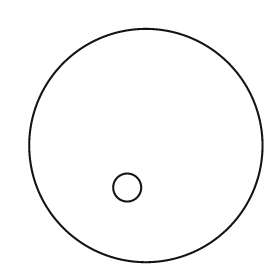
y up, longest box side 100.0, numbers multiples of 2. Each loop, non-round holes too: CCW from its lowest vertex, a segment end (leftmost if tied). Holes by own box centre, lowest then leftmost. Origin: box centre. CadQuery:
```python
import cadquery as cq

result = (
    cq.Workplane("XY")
    .moveTo(0.0, 0.0)
    .circle(50.0)
    .moveTo(-8.0, -18.0)
    .circle(6.0)
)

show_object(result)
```